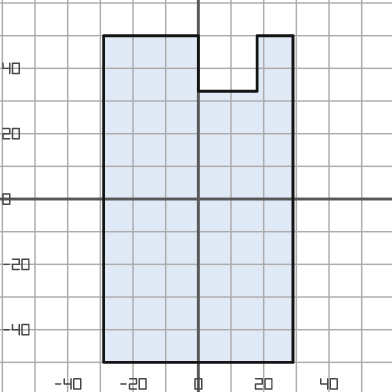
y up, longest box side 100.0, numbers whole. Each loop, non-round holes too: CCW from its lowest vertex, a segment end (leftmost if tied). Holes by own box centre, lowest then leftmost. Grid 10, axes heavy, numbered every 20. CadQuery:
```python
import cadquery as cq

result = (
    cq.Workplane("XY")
    .moveTo(-29.0, -50.0)
    .lineTo(29.0, -50.0)
    .lineTo(29.0, 50.0)
    .lineTo(18.0, 50.0)
    .lineTo(18.0, 33.0)
    .lineTo(0.0, 33.0)
    .lineTo(0.0, 50.0)
    .lineTo(-29.0, 50.0)
    .close()
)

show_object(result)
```